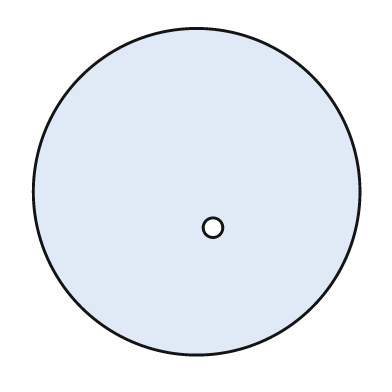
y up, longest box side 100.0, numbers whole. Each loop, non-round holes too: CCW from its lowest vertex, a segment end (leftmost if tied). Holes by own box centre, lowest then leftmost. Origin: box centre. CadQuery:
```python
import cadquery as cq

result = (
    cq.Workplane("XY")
    .moveTo(0.0, 0.0)
    .circle(50.0)
    .moveTo(5.0, -11.0)
    .circle(3.0)
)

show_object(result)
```